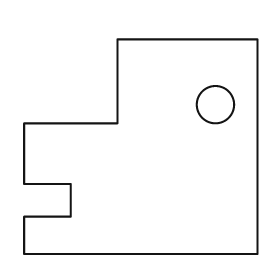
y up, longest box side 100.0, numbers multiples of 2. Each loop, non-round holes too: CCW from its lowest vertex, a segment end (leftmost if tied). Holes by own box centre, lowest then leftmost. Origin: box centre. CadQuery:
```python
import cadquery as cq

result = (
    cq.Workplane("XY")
    .moveTo(-50.0, -46.0)
    .lineTo(50.0, -46.0)
    .lineTo(50.0, 46.0)
    .lineTo(-10.0, 46.0)
    .lineTo(-10.0, 10.0)
    .lineTo(-50.0, 10.0)
    .lineTo(-50.0, -16.0)
    .lineTo(-30.0, -16.0)
    .lineTo(-30.0, -30.0)
    .lineTo(-50.0, -30.0)
    .close()
    .moveTo(32.0, 18.0)
    .circle(8.0)
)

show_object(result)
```